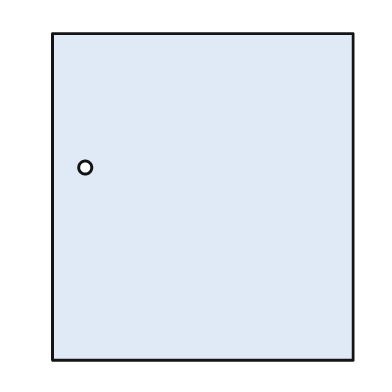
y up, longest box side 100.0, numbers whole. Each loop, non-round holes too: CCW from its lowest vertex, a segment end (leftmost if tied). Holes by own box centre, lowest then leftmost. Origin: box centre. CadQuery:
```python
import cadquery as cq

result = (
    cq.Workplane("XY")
    .moveTo(-46.0, -50.0)
    .lineTo(46.0, -50.0)
    .lineTo(46.0, 50.0)
    .lineTo(-46.0, 50.0)
    .close()
    .moveTo(-36.0, 9.0)
    .circle(2.0)
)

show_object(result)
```